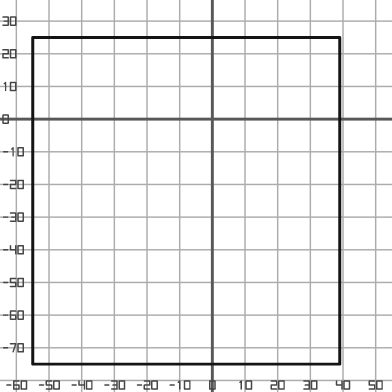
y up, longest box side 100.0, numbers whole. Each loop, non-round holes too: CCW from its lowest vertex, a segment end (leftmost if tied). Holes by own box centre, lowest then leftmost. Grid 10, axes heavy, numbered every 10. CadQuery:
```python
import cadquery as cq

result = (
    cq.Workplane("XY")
    .moveTo(-55.0, -75.0)
    .lineTo(39.0, -75.0)
    .lineTo(39.0, 25.0)
    .lineTo(-55.0, 25.0)
    .close()
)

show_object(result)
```